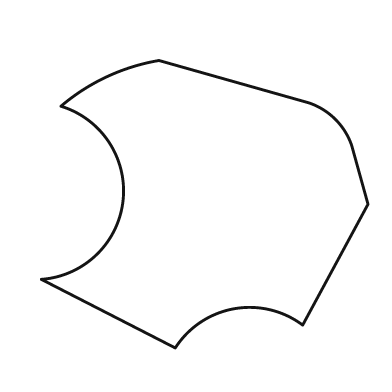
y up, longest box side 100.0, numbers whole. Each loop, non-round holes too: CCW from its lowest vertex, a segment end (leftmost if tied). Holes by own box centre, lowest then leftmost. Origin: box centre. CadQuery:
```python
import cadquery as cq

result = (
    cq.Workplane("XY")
    .moveTo(-9.0, -44.0)
    .threePointArc((9.0, -32.0), (30.0, -37.0))
    .lineTo(50.0, 0.0)
    .lineTo(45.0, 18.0)
    .threePointArc((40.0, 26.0), (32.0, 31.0))
    .lineTo(-14.0, 44.0)
    .threePointArc((-30.0, 39.0), (-44.0, 30.0))
    .threePointArc((-25.0, 1.0), (-50.0, -23.0))
    .close()
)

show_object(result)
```